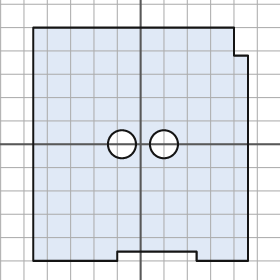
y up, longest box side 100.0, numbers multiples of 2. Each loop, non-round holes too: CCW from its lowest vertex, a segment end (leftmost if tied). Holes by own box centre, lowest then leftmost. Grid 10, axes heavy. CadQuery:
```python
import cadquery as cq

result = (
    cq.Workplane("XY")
    .moveTo(-46.0, -50.0)
    .lineTo(-10.0, -50.0)
    .lineTo(-10.0, -46.0)
    .lineTo(24.0, -46.0)
    .lineTo(24.0, -50.0)
    .lineTo(46.0, -50.0)
    .lineTo(46.0, 38.0)
    .lineTo(40.0, 38.0)
    .lineTo(40.0, 50.0)
    .lineTo(-46.0, 50.0)
    .close()
    .moveTo(-8.0, 0.0)
    .circle(6.0)
    .moveTo(10.0, 0.0)
    .circle(6.0)
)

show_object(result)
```